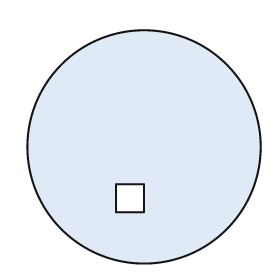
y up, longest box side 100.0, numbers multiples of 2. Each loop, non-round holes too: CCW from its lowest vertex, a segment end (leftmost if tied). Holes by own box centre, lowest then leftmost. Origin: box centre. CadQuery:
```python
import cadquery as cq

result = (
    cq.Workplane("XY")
    .moveTo(0.0, 0.0)
    .circle(50.0)
    .moveTo(-12.0, -28.0)
    .lineTo(0.0, -28.0)
    .lineTo(0.0, -16.0)
    .lineTo(-12.0, -16.0)
    .close()
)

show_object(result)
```